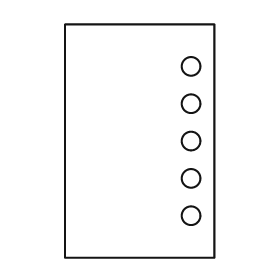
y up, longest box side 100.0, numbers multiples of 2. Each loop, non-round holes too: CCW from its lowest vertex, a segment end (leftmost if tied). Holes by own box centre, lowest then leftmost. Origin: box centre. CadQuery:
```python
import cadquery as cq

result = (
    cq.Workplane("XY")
    .moveTo(-32.0, -50.0)
    .lineTo(32.0, -50.0)
    .lineTo(32.0, 50.0)
    .lineTo(-32.0, 50.0)
    .close()
    .moveTo(22.0, -32.0)
    .circle(4.0)
    .moveTo(22.0, -16.0)
    .circle(4.0)
    .moveTo(22.0, 0.0)
    .circle(4.0)
    .moveTo(22.0, 16.0)
    .circle(4.0)
    .moveTo(22.0, 32.0)
    .circle(4.0)
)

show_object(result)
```